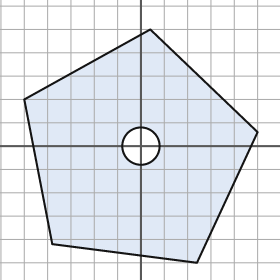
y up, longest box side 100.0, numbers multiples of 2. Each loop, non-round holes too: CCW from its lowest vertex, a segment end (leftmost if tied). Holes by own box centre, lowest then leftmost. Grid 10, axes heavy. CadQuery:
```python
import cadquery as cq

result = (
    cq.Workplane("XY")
    .moveTo(24.0, -50.0)
    .lineTo(50.0, 6.0)
    .lineTo(4.0, 50.0)
    .lineTo(-50.0, 20.0)
    .lineTo(-38.0, -42.0)
    .close()
    .moveTo(0.0, 0.0)
    .circle(8.0)
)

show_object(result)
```